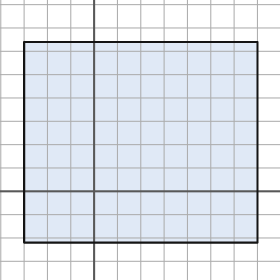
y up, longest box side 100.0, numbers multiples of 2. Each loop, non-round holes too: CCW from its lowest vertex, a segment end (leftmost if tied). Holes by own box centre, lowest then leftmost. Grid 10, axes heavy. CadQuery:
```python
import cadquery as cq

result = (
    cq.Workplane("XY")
    .moveTo(-30.0, -22.0)
    .lineTo(70.0, -22.0)
    .lineTo(70.0, 64.0)
    .lineTo(-30.0, 64.0)
    .close()
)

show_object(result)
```